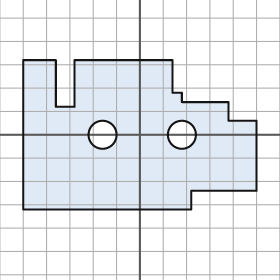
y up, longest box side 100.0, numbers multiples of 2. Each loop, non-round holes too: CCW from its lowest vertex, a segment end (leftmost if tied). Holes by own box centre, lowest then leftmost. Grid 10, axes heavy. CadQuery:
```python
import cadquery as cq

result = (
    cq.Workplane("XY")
    .moveTo(-50.0, -32.0)
    .lineTo(22.0, -32.0)
    .lineTo(22.0, -24.0)
    .lineTo(50.0, -24.0)
    .lineTo(50.0, 6.0)
    .lineTo(38.0, 6.0)
    .lineTo(38.0, 14.0)
    .lineTo(18.0, 14.0)
    .lineTo(18.0, 18.0)
    .lineTo(14.0, 18.0)
    .lineTo(14.0, 32.0)
    .lineTo(-28.0, 32.0)
    .lineTo(-28.0, 12.0)
    .lineTo(-36.0, 12.0)
    .lineTo(-36.0, 32.0)
    .lineTo(-50.0, 32.0)
    .close()
    .moveTo(-16.0, 0.0)
    .circle(6.0)
    .moveTo(18.0, 0.0)
    .circle(6.0)
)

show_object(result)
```